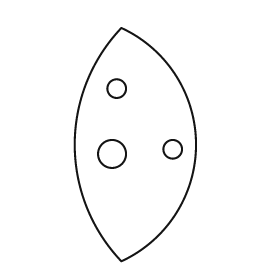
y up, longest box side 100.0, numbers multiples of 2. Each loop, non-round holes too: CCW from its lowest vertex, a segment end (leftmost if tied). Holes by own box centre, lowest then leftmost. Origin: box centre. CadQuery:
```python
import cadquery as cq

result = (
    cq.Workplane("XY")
    .moveTo(-6.0, -50.0)
    .threePointArc((26.0, 0.0), (-6.0, 50.0))
    .threePointArc((-26.0, 0.0), (-6.0, -50.0))
    .close()
    .moveTo(-10.0, -4.0)
    .circle(6.0)
    .moveTo(16.0, -2.0)
    .circle(4.0)
    .moveTo(-8.0, 24.0)
    .circle(4.0)
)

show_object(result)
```